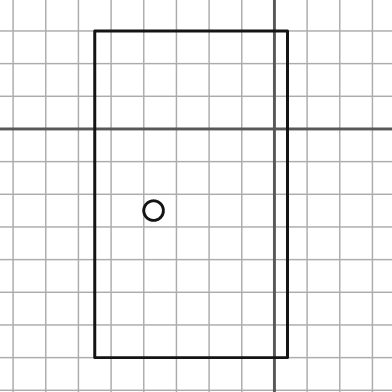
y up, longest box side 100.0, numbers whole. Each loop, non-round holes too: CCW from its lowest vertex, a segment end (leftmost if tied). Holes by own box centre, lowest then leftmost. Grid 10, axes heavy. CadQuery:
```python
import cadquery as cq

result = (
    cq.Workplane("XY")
    .moveTo(-55.0, -70.0)
    .lineTo(4.0, -70.0)
    .lineTo(4.0, 30.0)
    .lineTo(-55.0, 30.0)
    .close()
    .moveTo(-37.0, -25.0)
    .circle(3.0)
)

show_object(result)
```